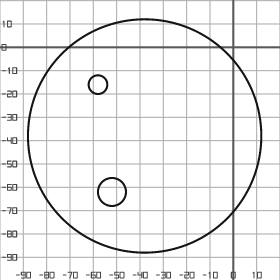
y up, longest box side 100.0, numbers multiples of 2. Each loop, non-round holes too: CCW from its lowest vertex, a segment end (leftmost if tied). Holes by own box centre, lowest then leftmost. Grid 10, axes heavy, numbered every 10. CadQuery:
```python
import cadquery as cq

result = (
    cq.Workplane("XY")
    .moveTo(-38.0, -38.0)
    .circle(50.0)
    .moveTo(-52.0, -62.0)
    .circle(6.0)
    .moveTo(-58.0, -16.0)
    .circle(4.0)
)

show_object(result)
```